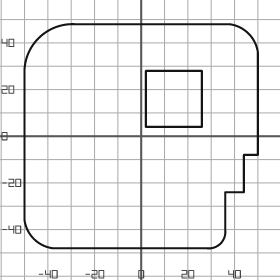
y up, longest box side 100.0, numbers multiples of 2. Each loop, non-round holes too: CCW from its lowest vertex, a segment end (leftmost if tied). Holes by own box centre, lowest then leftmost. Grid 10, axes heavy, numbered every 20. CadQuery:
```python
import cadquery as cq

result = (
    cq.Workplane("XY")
    .moveTo(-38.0, -48.0)
    .lineTo(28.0, -48.0)
    .threePointArc((34.0, -46.0), (36.0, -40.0))
    .lineTo(36.0, -24.0)
    .lineTo(44.0, -24.0)
    .lineTo(44.0, -8.0)
    .lineTo(50.0, -8.0)
    .lineTo(50.0, 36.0)
    .threePointArc((46.0, 44.0), (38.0, 48.0))
    .lineTo(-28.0, 48.0)
    .threePointArc((-44.0, 42.0), (-50.0, 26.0))
    .lineTo(-50.0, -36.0)
    .threePointArc((-46.0, -44.0), (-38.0, -48.0))
    .close()
    .moveTo(2.0, 4.0)
    .lineTo(26.0, 4.0)
    .lineTo(26.0, 28.0)
    .lineTo(2.0, 28.0)
    .close()
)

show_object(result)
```